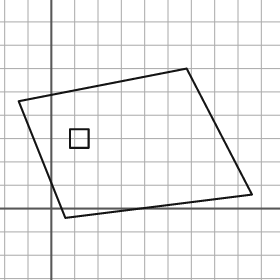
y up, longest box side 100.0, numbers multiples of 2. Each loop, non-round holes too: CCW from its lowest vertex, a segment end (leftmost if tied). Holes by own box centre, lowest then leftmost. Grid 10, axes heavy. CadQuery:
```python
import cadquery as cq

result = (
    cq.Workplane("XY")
    .moveTo(6.0, -4.0)
    .lineTo(86.0, 6.0)
    .lineTo(58.0, 60.0)
    .lineTo(-14.0, 46.0)
    .close()
    .moveTo(8.0, 26.0)
    .lineTo(16.0, 26.0)
    .lineTo(16.0, 34.0)
    .lineTo(8.0, 34.0)
    .close()
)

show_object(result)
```